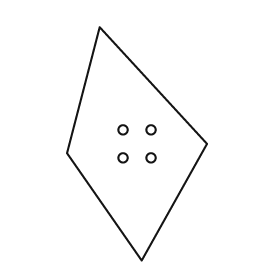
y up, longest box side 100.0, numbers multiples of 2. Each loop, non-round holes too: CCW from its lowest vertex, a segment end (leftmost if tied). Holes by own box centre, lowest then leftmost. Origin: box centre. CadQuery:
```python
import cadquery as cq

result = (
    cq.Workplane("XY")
    .moveTo(2.0, -50.0)
    .lineTo(30.0, 0.0)
    .lineTo(-16.0, 50.0)
    .lineTo(-30.0, -4.0)
    .close()
    .moveTo(-6.0, -6.0)
    .circle(2.0)
    .moveTo(6.0, -6.0)
    .circle(2.0)
    .moveTo(-6.0, 6.0)
    .circle(2.0)
    .moveTo(6.0, 6.0)
    .circle(2.0)
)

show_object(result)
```